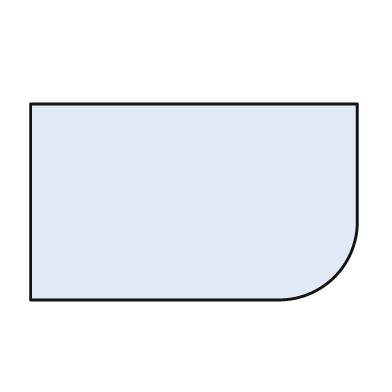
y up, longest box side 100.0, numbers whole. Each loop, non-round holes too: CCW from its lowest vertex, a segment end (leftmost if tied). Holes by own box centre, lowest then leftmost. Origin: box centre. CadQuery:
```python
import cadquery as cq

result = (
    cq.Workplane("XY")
    .moveTo(-50.0, -30.0)
    .lineTo(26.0, -30.0)
    .threePointArc((43.0, -23.0), (50.0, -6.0))
    .lineTo(50.0, 30.0)
    .lineTo(-50.0, 30.0)
    .close()
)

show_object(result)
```